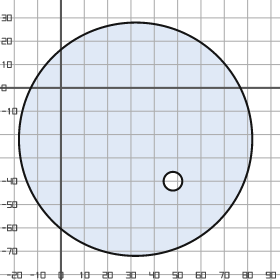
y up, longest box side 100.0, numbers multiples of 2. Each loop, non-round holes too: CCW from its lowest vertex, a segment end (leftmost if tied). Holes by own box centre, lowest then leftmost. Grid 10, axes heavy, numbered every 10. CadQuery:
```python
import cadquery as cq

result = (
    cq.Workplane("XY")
    .moveTo(32.0, -22.0)
    .circle(50.0)
    .moveTo(48.0, -40.0)
    .circle(4.0)
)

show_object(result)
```